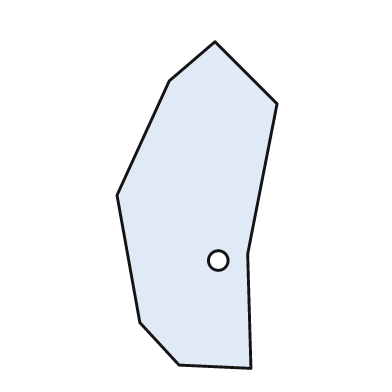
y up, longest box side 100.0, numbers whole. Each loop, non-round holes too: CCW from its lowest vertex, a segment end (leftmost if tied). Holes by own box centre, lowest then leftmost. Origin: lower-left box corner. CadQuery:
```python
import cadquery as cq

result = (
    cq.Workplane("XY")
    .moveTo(41.0, 0.0)
    .lineTo(40.0, 35.0)
    .lineTo(49.0, 81.0)
    .lineTo(30.0, 100.0)
    .lineTo(16.0, 88.0)
    .lineTo(0.0, 53.0)
    .lineTo(7.0, 14.0)
    .lineTo(19.0, 1.0)
    .close()
    .moveTo(31.0, 33.0)
    .circle(3.0)
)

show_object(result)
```